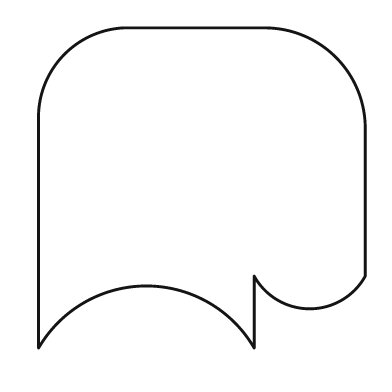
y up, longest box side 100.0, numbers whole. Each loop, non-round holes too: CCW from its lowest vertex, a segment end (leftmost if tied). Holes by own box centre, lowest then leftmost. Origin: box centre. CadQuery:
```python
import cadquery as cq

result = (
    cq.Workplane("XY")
    .moveTo(-50.0, -49.0)
    .threePointArc((-17.0, -30.0), (16.0, -49.0))
    .lineTo(16.0, -27.0)
    .threePointArc((33.0, -37.0), (50.0, -27.0))
    .lineTo(50.0, 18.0)
    .threePointArc((41.0, 40.0), (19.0, 49.0))
    .lineTo(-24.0, 49.0)
    .threePointArc((-42.0, 41.0), (-50.0, 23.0))
    .close()
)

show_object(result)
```